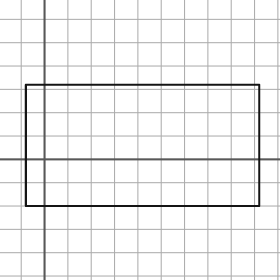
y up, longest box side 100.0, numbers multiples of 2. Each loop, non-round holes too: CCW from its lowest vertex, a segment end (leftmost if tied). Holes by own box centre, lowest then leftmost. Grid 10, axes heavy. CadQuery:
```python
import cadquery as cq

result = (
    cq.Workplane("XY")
    .moveTo(-8.0, -20.0)
    .lineTo(92.0, -20.0)
    .lineTo(92.0, 32.0)
    .lineTo(-8.0, 32.0)
    .close()
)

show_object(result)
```